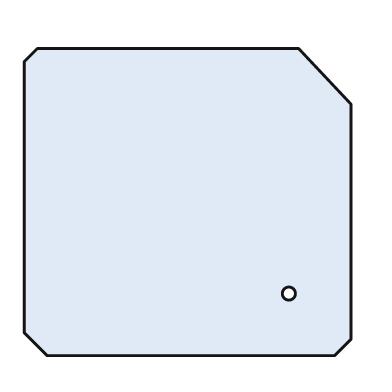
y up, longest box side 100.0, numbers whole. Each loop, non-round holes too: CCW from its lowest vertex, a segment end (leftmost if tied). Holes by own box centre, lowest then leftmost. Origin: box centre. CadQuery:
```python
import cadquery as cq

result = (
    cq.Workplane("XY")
    .moveTo(-43.0, -47.0)
    .lineTo(45.0, -47.0)
    .lineTo(50.0, -42.0)
    .lineTo(50.0, 30.0)
    .lineTo(34.0, 47.0)
    .lineTo(-46.0, 47.0)
    .lineTo(-50.0, 43.0)
    .lineTo(-50.0, -40.0)
    .close()
    .moveTo(31.0, -28.0)
    .circle(2.0)
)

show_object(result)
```